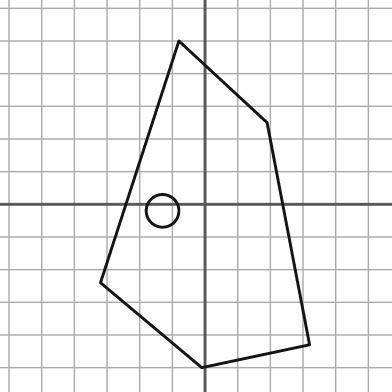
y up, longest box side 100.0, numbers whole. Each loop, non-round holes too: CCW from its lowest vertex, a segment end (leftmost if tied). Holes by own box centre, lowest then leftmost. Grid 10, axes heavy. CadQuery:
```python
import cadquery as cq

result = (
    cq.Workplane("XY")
    .moveTo(-1.0, -50.0)
    .lineTo(32.0, -43.0)
    .lineTo(19.0, 25.0)
    .lineTo(-8.0, 50.0)
    .lineTo(-32.0, -24.0)
    .close()
    .moveTo(-13.0, -2.0)
    .circle(5.0)
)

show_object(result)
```